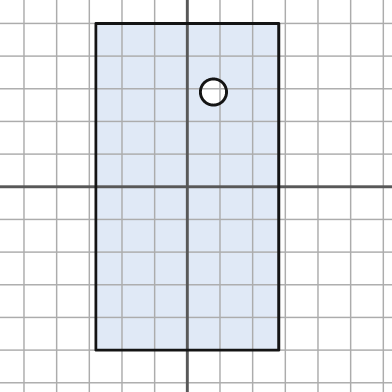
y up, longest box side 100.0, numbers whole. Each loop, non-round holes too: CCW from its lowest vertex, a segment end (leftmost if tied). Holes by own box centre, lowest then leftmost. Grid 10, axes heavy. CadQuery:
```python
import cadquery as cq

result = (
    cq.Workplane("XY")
    .moveTo(-28.0, -50.0)
    .lineTo(28.0, -50.0)
    .lineTo(28.0, 50.0)
    .lineTo(-28.0, 50.0)
    .close()
    .moveTo(8.0, 29.0)
    .circle(4.0)
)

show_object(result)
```